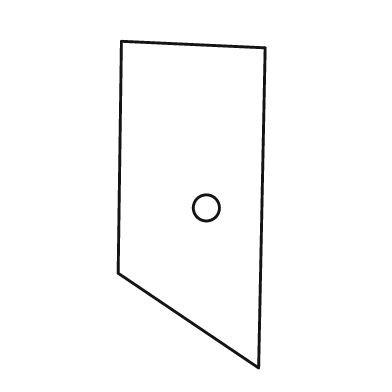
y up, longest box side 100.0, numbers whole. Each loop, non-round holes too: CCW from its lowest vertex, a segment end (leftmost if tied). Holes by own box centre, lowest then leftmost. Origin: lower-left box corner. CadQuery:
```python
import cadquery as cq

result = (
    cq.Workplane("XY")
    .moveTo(43.0, 0.0)
    .lineTo(45.0, 98.0)
    .lineTo(1.0, 100.0)
    .lineTo(0.0, 29.0)
    .close()
    .moveTo(27.0, 49.0)
    .circle(4.0)
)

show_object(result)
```